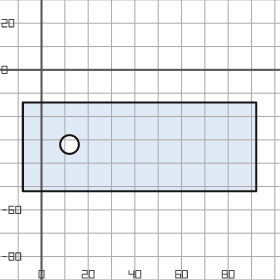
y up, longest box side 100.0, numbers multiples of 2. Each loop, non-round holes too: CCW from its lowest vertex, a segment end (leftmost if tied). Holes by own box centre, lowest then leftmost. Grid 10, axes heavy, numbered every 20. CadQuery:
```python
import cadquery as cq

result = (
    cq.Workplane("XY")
    .moveTo(-8.0, -52.0)
    .lineTo(92.0, -52.0)
    .lineTo(92.0, -14.0)
    .lineTo(-8.0, -14.0)
    .close()
    .moveTo(12.0, -32.0)
    .circle(4.0)
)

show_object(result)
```